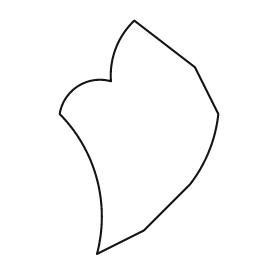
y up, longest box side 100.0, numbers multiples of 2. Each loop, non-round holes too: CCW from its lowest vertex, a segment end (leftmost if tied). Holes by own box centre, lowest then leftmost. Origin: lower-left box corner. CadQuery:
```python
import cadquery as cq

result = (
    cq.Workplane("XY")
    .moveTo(16.0, 0.0)
    .lineTo(36.0, 10.0)
    .lineTo(56.0, 30.0)
    .threePointArc((64.0, 44.0), (68.0, 60.0))
    .lineTo(58.0, 80.0)
    .lineTo(32.0, 100.0)
    .threePointArc((24.0, 88.0), (22.0, 74.0))
    .threePointArc((8.0, 72.0), (0.0, 60.0))
    .threePointArc((16.0, 32.0), (16.0, 0.0))
    .close()
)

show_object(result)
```